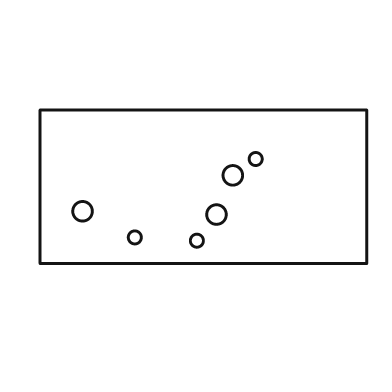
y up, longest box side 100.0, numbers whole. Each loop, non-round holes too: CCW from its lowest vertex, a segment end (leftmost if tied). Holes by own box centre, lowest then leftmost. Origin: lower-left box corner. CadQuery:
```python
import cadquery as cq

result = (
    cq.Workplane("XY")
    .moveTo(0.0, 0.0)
    .lineTo(100.0, 0.0)
    .lineTo(100.0, 47.0)
    .lineTo(0.0, 47.0)
    .close()
    .moveTo(48.0, 7.0)
    .circle(2.0)
    .moveTo(29.0, 8.0)
    .circle(2.0)
    .moveTo(54.0, 15.0)
    .circle(3.0)
    .moveTo(13.0, 16.0)
    .circle(3.0)
    .moveTo(59.0, 27.0)
    .circle(3.0)
    .moveTo(66.0, 32.0)
    .circle(2.0)
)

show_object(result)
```